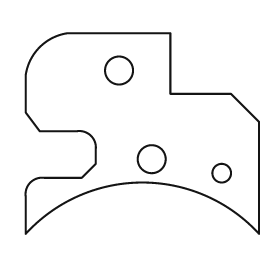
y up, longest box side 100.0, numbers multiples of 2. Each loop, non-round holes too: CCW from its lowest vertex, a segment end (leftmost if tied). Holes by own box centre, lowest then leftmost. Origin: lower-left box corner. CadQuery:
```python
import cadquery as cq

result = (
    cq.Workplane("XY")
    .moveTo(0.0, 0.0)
    .threePointArc((50.0, 22.0), (100.0, 0.0))
    .lineTo(100.0, 48.0)
    .lineTo(88.0, 60.0)
    .lineTo(62.0, 60.0)
    .lineTo(62.0, 86.0)
    .lineTo(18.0, 86.0)
    .threePointArc((6.0, 80.0), (0.0, 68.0))
    .lineTo(0.0, 52.0)
    .lineTo(6.0, 44.0)
    .lineTo(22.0, 44.0)
    .threePointArc((28.0, 42.0), (30.0, 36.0))
    .lineTo(30.0, 30.0)
    .lineTo(24.0, 24.0)
    .lineTo(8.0, 24.0)
    .threePointArc((2.0, 22.0), (0.0, 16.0))
    .close()
    .moveTo(84.0, 26.0)
    .circle(4.0)
    .moveTo(54.0, 32.0)
    .circle(6.0)
    .moveTo(40.0, 70.0)
    .circle(6.0)
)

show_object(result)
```